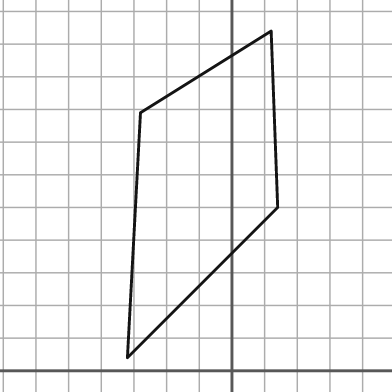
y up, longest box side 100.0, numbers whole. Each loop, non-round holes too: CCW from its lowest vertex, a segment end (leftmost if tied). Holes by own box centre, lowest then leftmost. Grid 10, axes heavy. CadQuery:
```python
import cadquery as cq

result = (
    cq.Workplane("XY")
    .moveTo(-32.0, 4.0)
    .lineTo(14.0, 50.0)
    .lineTo(12.0, 104.0)
    .lineTo(-28.0, 79.0)
    .close()
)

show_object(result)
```